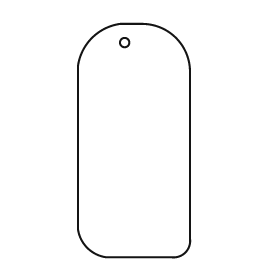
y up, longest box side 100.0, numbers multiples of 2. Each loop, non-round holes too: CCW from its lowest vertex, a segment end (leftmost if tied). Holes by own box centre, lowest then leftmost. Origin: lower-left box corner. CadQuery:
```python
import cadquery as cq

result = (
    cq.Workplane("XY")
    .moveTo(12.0, 0.0)
    .lineTo(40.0, 0.0)
    .threePointArc((46.0, 2.0), (48.0, 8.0))
    .lineTo(48.0, 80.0)
    .threePointArc((42.0, 94.0), (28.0, 100.0))
    .lineTo(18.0, 100.0)
    .threePointArc((6.0, 94.0), (0.0, 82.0))
    .lineTo(0.0, 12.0)
    .threePointArc((4.0, 4.0), (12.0, 0.0))
    .close()
    .moveTo(20.0, 92.0)
    .circle(2.0)
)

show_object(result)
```